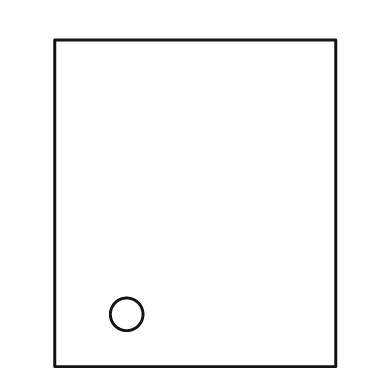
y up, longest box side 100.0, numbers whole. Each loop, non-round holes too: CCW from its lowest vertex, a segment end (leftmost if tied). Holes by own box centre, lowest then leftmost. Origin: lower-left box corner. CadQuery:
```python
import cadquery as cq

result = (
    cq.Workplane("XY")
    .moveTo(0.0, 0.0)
    .lineTo(86.0, 0.0)
    .lineTo(86.0, 100.0)
    .lineTo(0.0, 100.0)
    .close()
    .moveTo(22.0, 16.0)
    .circle(5.0)
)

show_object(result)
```